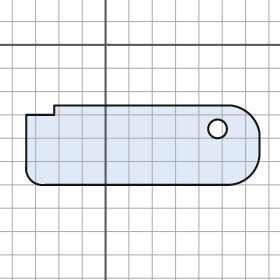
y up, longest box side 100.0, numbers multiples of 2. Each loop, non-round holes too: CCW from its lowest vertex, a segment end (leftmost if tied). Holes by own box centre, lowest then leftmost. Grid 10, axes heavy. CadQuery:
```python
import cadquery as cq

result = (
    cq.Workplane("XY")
    .moveTo(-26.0, -60.0)
    .lineTo(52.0, -60.0)
    .threePointArc((62.0, -56.0), (66.0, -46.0))
    .lineTo(66.0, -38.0)
    .threePointArc((62.0, -30.0), (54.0, -26.0))
    .lineTo(-22.0, -26.0)
    .lineTo(-22.0, -30.0)
    .lineTo(-34.0, -30.0)
    .lineTo(-34.0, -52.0)
    .threePointArc((-32.0, -58.0), (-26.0, -60.0))
    .close()
    .moveTo(48.0, -36.0)
    .circle(4.0)
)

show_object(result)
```